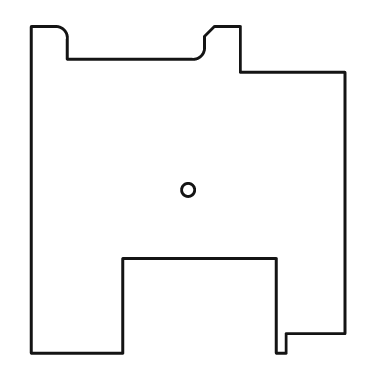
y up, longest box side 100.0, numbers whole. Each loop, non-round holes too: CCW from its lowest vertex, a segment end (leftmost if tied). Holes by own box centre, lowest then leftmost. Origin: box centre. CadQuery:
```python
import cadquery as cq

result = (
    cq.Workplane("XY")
    .moveTo(-48.0, -50.0)
    .lineTo(-20.0, -50.0)
    .lineTo(-20.0, -21.0)
    .lineTo(27.0, -21.0)
    .lineTo(27.0, -50.0)
    .lineTo(30.0, -50.0)
    .lineTo(30.0, -44.0)
    .lineTo(48.0, -44.0)
    .lineTo(48.0, 36.0)
    .lineTo(16.0, 36.0)
    .lineTo(16.0, 50.0)
    .lineTo(8.0, 50.0)
    .lineTo(5.0, 47.0)
    .lineTo(5.0, 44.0)
    .threePointArc((4.0, 41.0), (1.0, 40.0))
    .lineTo(-37.0, 40.0)
    .lineTo(-37.0, 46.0)
    .threePointArc((-38.0, 49.0), (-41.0, 50.0))
    .lineTo(-48.0, 50.0)
    .close()
    .moveTo(0.0, 0.0)
    .circle(2.0)
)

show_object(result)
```